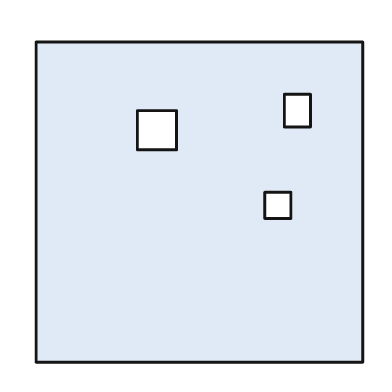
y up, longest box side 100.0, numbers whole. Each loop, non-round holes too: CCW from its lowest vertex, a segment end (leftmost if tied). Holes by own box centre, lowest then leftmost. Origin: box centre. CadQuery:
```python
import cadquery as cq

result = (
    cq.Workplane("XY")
    .moveTo(-50.0, -49.0)
    .lineTo(50.0, -49.0)
    .lineTo(50.0, 49.0)
    .lineTo(-50.0, 49.0)
    .close()
    .moveTo(20.0, -5.0)
    .lineTo(28.0, -5.0)
    .lineTo(28.0, 3.0)
    .lineTo(20.0, 3.0)
    .close()
    .moveTo(-19.0, 16.0)
    .lineTo(-7.0, 16.0)
    .lineTo(-7.0, 28.0)
    .lineTo(-19.0, 28.0)
    .close()
    .moveTo(26.0, 23.0)
    .lineTo(34.0, 23.0)
    .lineTo(34.0, 33.0)
    .lineTo(26.0, 33.0)
    .close()
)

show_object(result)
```